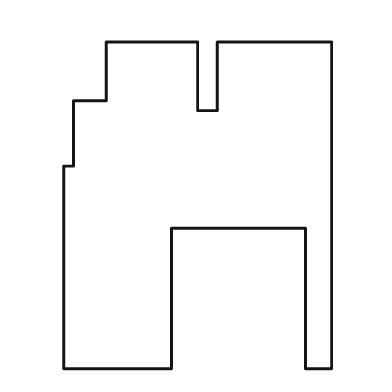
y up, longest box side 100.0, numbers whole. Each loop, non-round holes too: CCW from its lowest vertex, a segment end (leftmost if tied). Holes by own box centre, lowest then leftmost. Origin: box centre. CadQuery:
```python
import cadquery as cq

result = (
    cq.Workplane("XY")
    .moveTo(-41.0, -50.0)
    .lineTo(-8.0, -50.0)
    .lineTo(-8.0, -7.0)
    .lineTo(33.0, -7.0)
    .lineTo(33.0, -50.0)
    .lineTo(41.0, -50.0)
    .lineTo(41.0, 50.0)
    .lineTo(6.0, 50.0)
    .lineTo(6.0, 29.0)
    .lineTo(0.0, 29.0)
    .lineTo(0.0, 50.0)
    .lineTo(-28.0, 50.0)
    .lineTo(-28.0, 32.0)
    .lineTo(-38.0, 32.0)
    .lineTo(-38.0, 12.0)
    .lineTo(-41.0, 12.0)
    .close()
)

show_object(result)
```